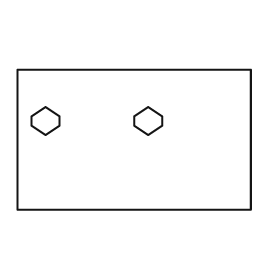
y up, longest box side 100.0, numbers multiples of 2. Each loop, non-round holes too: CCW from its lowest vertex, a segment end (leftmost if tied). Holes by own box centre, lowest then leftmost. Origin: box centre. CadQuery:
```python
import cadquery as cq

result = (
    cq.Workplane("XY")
    .moveTo(-50.0, -30.0)
    .lineTo(50.0, -30.0)
    .lineTo(50.0, 30.0)
    .lineTo(-50.0, 30.0)
    .close()
    .moveTo(-38.0, 2.0)
    .lineTo(-32.0, 6.0)
    .lineTo(-32.0, 10.0)
    .lineTo(-38.0, 14.0)
    .lineTo(-44.0, 10.0)
    .lineTo(-44.0, 6.0)
    .close()
    .moveTo(6.0, 2.0)
    .lineTo(12.0, 6.0)
    .lineTo(12.0, 10.0)
    .lineTo(6.0, 14.0)
    .lineTo(0.0, 10.0)
    .lineTo(0.0, 6.0)
    .close()
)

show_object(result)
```